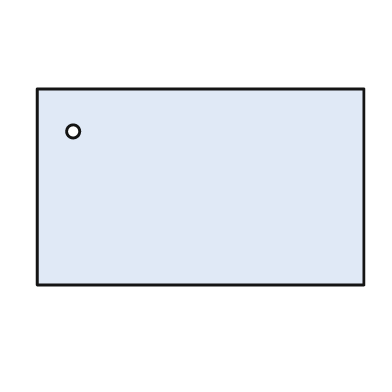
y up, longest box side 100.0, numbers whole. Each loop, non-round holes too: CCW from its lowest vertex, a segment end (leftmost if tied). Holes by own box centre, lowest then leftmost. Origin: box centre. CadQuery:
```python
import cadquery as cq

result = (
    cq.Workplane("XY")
    .moveTo(-50.0, -30.0)
    .lineTo(50.0, -30.0)
    .lineTo(50.0, 30.0)
    .lineTo(-50.0, 30.0)
    .close()
    .moveTo(-39.0, 17.0)
    .circle(2.0)
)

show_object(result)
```